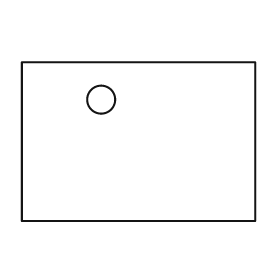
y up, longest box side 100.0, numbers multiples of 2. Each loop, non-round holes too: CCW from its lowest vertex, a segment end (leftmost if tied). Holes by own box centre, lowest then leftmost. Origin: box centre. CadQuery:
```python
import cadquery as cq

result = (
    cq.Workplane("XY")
    .moveTo(-50.0, -34.0)
    .lineTo(50.0, -34.0)
    .lineTo(50.0, 34.0)
    .lineTo(-50.0, 34.0)
    .close()
    .moveTo(-16.0, 18.0)
    .circle(6.0)
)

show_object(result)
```